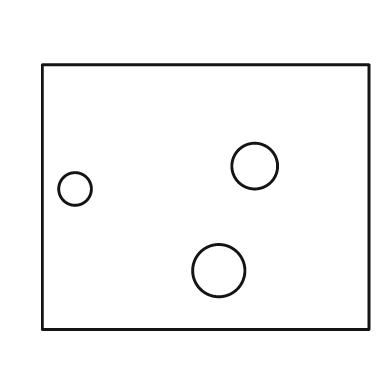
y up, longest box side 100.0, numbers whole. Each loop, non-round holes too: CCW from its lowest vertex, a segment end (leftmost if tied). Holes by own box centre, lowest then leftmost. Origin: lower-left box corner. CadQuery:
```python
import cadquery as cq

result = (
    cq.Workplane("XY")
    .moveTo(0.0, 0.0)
    .lineTo(100.0, 0.0)
    .lineTo(100.0, 81.0)
    .lineTo(0.0, 81.0)
    .close()
    .moveTo(54.0, 18.0)
    .circle(8.0)
    .moveTo(10.0, 43.0)
    .circle(5.0)
    .moveTo(65.0, 50.0)
    .circle(7.0)
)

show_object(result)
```